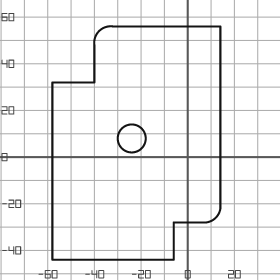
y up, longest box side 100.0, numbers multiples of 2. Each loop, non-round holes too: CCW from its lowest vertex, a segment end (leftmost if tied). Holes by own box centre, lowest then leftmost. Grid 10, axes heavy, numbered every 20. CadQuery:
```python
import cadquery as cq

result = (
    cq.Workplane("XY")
    .moveTo(-58.0, -44.0)
    .lineTo(-6.0, -44.0)
    .lineTo(-6.0, -28.0)
    .lineTo(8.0, -28.0)
    .threePointArc((12.0, -26.0), (14.0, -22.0))
    .lineTo(14.0, 56.0)
    .lineTo(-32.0, 56.0)
    .threePointArc((-38.0, 54.0), (-40.0, 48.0))
    .lineTo(-40.0, 32.0)
    .lineTo(-58.0, 32.0)
    .close()
    .moveTo(-24.0, 8.0)
    .circle(6.0)
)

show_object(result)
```